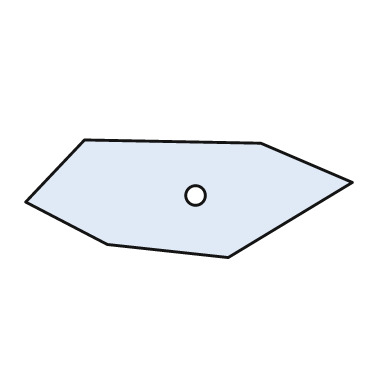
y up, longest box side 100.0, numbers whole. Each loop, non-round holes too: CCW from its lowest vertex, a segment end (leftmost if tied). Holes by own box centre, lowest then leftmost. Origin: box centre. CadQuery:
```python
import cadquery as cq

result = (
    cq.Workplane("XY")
    .moveTo(12.0, -18.0)
    .lineTo(50.0, 5.0)
    .lineTo(22.0, 17.0)
    .lineTo(-32.0, 18.0)
    .lineTo(-50.0, -1.0)
    .lineTo(-25.0, -14.0)
    .close()
    .moveTo(2.0, 1.0)
    .circle(3.0)
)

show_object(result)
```